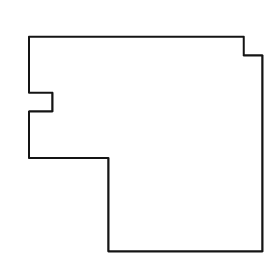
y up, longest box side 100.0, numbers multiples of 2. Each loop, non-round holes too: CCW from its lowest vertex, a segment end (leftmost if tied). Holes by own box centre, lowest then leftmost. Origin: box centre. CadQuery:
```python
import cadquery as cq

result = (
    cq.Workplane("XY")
    .moveTo(-16.0, -46.0)
    .lineTo(50.0, -46.0)
    .lineTo(50.0, 38.0)
    .lineTo(42.0, 38.0)
    .lineTo(42.0, 46.0)
    .lineTo(-50.0, 46.0)
    .lineTo(-50.0, 22.0)
    .lineTo(-40.0, 22.0)
    .lineTo(-40.0, 14.0)
    .lineTo(-50.0, 14.0)
    .lineTo(-50.0, -6.0)
    .lineTo(-16.0, -6.0)
    .close()
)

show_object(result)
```